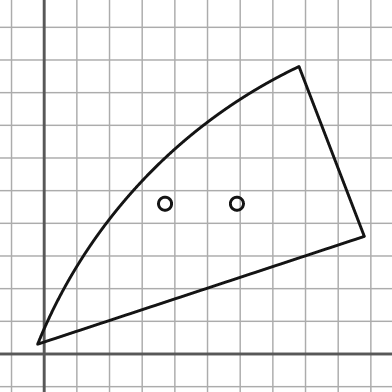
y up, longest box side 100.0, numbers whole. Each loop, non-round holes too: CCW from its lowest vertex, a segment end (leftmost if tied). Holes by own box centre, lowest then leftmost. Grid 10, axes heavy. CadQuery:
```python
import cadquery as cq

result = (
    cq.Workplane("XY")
    .moveTo(-2.0, 3.0)
    .lineTo(98.0, 36.0)
    .lineTo(78.0, 88.0)
    .threePointArc((30.0, 53.0), (-2.0, 3.0))
    .close()
    .moveTo(37.0, 46.0)
    .circle(2.0)
    .moveTo(59.0, 46.0)
    .circle(2.0)
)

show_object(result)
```